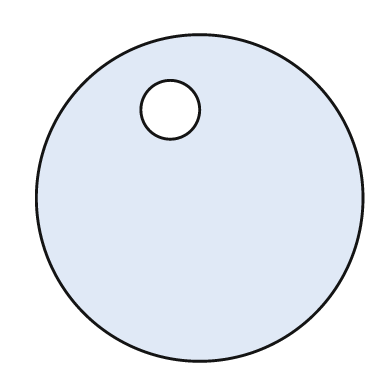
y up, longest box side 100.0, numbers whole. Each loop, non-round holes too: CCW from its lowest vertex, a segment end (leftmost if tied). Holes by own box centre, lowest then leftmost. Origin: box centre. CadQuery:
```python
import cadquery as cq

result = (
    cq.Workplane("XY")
    .moveTo(0.0, 0.0)
    .circle(50.0)
    .moveTo(-9.0, 27.0)
    .circle(9.0)
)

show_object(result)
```